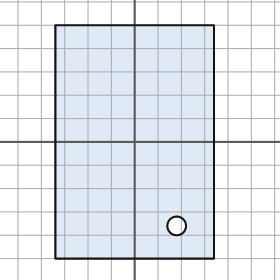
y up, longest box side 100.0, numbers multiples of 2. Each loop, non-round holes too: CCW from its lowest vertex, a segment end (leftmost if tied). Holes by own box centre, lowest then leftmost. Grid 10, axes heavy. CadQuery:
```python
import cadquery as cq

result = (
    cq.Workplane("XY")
    .moveTo(-34.0, -50.0)
    .lineTo(34.0, -50.0)
    .lineTo(34.0, 50.0)
    .lineTo(-34.0, 50.0)
    .close()
    .moveTo(18.0, -36.0)
    .circle(4.0)
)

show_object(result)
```